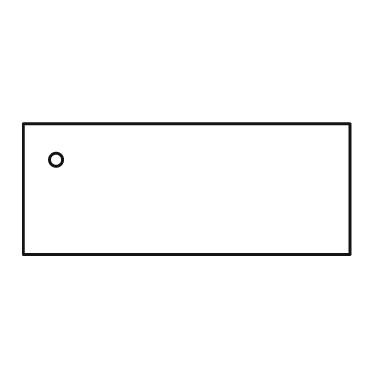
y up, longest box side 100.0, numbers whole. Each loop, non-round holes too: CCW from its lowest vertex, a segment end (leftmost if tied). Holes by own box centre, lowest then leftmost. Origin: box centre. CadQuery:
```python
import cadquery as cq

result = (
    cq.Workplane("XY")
    .moveTo(-50.0, -20.0)
    .lineTo(50.0, -20.0)
    .lineTo(50.0, 20.0)
    .lineTo(-50.0, 20.0)
    .close()
    .moveTo(-40.0, 9.0)
    .circle(2.0)
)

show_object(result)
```